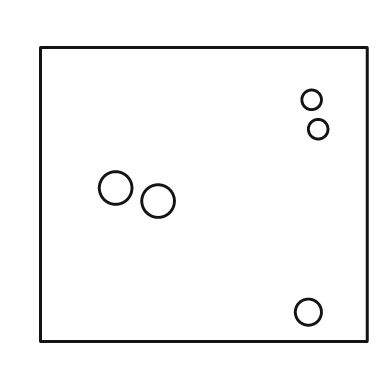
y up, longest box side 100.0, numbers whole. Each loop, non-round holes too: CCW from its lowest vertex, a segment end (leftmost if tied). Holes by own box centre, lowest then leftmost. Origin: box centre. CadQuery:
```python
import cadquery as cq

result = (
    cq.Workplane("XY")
    .moveTo(-50.0, -45.0)
    .lineTo(50.0, -45.0)
    .lineTo(50.0, 45.0)
    .lineTo(-50.0, 45.0)
    .close()
    .moveTo(32.0, -36.0)
    .circle(4.0)
    .moveTo(-14.0, -2.0)
    .circle(5.0)
    .moveTo(-27.0, 2.0)
    .circle(5.0)
    .moveTo(35.0, 20.0)
    .circle(3.0)
    .moveTo(33.0, 29.0)
    .circle(3.0)
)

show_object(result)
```